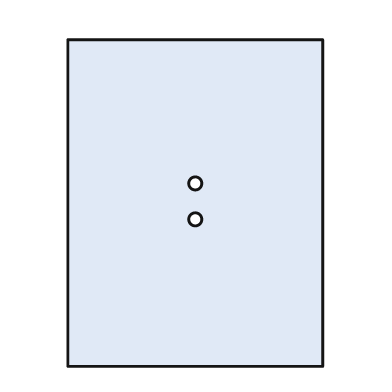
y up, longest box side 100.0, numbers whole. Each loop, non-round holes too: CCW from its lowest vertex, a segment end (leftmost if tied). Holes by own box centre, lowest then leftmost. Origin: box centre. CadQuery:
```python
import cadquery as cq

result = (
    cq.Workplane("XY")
    .moveTo(-39.0, -50.0)
    .lineTo(39.0, -50.0)
    .lineTo(39.0, 50.0)
    .lineTo(-39.0, 50.0)
    .close()
    .moveTo(0.0, -5.0)
    .circle(2.0)
    .moveTo(0.0, 6.0)
    .circle(2.0)
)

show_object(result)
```